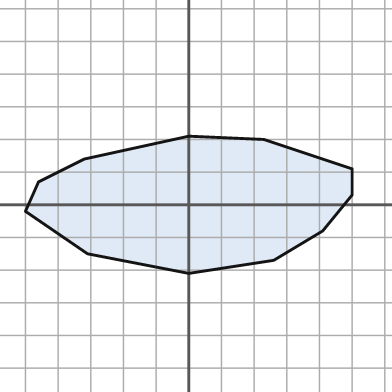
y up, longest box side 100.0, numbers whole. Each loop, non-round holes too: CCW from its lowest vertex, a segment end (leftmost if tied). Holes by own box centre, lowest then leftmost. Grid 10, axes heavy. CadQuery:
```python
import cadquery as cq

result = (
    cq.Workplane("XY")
    .moveTo(0.0, -21.0)
    .lineTo(26.0, -17.0)
    .lineTo(41.0, -8.0)
    .lineTo(50.0, 3.0)
    .lineTo(50.0, 11.0)
    .lineTo(23.0, 20.0)
    .lineTo(0.0, 21.0)
    .lineTo(-32.0, 14.0)
    .lineTo(-46.0, 7.0)
    .lineTo(-50.0, -2.0)
    .lineTo(-31.0, -15.0)
    .close()
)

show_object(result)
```